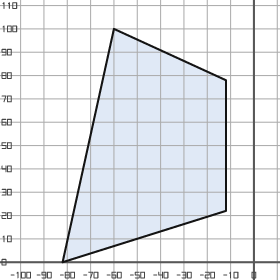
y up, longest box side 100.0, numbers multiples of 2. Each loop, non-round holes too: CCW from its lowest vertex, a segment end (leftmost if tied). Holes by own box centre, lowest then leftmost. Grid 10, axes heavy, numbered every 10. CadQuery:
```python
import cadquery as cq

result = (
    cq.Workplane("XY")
    .moveTo(-82.0, 0.0)
    .lineTo(-12.0, 22.0)
    .lineTo(-12.0, 78.0)
    .lineTo(-60.0, 100.0)
    .close()
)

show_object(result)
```